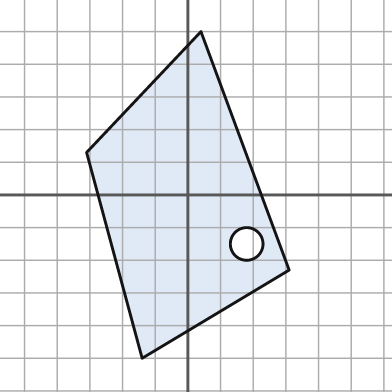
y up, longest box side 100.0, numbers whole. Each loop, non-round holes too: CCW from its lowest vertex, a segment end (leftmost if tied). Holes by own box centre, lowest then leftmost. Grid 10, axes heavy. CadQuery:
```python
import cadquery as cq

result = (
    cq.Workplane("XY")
    .moveTo(-14.0, -50.0)
    .lineTo(31.0, -23.0)
    .lineTo(4.0, 50.0)
    .lineTo(-31.0, 13.0)
    .close()
    .moveTo(18.0, -15.0)
    .circle(5.0)
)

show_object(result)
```